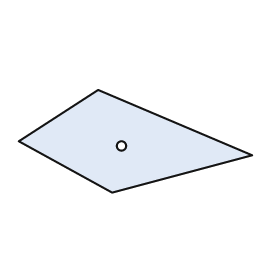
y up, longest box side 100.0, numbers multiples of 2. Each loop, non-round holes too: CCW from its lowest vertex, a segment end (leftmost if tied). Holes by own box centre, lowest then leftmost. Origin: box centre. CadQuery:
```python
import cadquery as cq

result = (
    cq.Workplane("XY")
    .moveTo(-10.0, -22.0)
    .lineTo(50.0, -6.0)
    .lineTo(-16.0, 22.0)
    .lineTo(-50.0, 0.0)
    .close()
    .moveTo(-6.0, -2.0)
    .circle(2.0)
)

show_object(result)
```